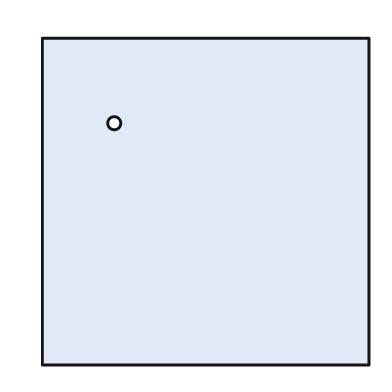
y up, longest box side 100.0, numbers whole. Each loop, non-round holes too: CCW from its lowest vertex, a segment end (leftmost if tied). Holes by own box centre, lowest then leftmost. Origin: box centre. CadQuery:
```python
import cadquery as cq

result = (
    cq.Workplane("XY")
    .moveTo(-50.0, -50.0)
    .lineTo(50.0, -50.0)
    .lineTo(50.0, 50.0)
    .lineTo(-50.0, 50.0)
    .close()
    .moveTo(-28.0, 24.0)
    .circle(2.0)
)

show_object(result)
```